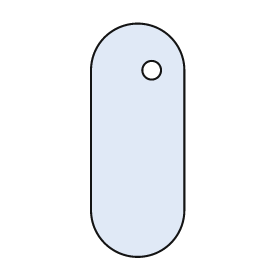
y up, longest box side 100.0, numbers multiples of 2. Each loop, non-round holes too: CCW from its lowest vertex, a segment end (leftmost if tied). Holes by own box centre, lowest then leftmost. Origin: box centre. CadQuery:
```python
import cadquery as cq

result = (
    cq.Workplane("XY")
    .moveTo(-20.0, -30.0)
    .threePointArc((0.0, -50.0), (20.0, -30.0))
    .lineTo(20.0, 30.0)
    .threePointArc((0.0, 50.0), (-20.0, 30.0))
    .close()
    .moveTo(6.0, 30.0)
    .circle(4.0)
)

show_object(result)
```